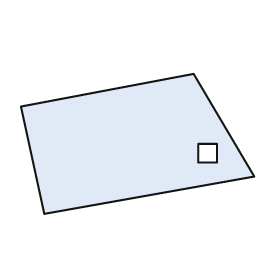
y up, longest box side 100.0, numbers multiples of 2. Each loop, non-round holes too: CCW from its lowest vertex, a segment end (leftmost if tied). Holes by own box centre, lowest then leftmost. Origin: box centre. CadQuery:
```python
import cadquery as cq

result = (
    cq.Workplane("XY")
    .moveTo(-40.0, -30.0)
    .lineTo(50.0, -14.0)
    .lineTo(24.0, 30.0)
    .lineTo(-50.0, 16.0)
    .close()
    .moveTo(26.0, -8.0)
    .lineTo(34.0, -8.0)
    .lineTo(34.0, 0.0)
    .lineTo(26.0, 0.0)
    .close()
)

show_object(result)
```